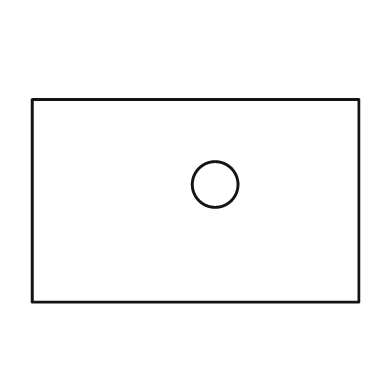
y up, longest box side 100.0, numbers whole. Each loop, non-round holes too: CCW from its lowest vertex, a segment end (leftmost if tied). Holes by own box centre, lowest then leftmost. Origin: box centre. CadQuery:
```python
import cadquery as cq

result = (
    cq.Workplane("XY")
    .moveTo(-50.0, -31.0)
    .lineTo(50.0, -31.0)
    .lineTo(50.0, 31.0)
    .lineTo(-50.0, 31.0)
    .close()
    .moveTo(6.0, 5.0)
    .circle(7.0)
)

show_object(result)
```